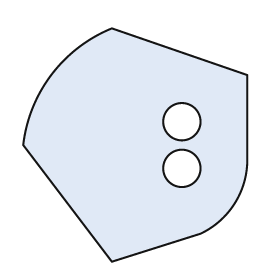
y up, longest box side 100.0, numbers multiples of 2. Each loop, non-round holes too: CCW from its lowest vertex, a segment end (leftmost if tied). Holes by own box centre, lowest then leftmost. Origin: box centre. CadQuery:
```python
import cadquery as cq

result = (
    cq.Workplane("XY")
    .moveTo(-10.0, -50.0)
    .lineTo(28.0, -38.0)
    .threePointArc((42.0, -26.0), (48.0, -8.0))
    .lineTo(48.0, 30.0)
    .lineTo(-10.0, 50.0)
    .threePointArc((-36.0, 30.0), (-48.0, 0.0))
    .close()
    .moveTo(20.0, -10.0)
    .circle(8.0)
    .moveTo(20.0, 10.0)
    .circle(8.0)
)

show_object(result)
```